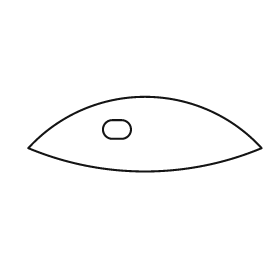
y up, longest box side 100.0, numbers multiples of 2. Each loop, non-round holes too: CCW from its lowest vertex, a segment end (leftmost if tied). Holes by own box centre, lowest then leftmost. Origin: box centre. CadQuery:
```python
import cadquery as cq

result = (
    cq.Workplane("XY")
    .moveTo(-50.0, -6.0)
    .threePointArc((0.0, -16.0), (50.0, -6.0))
    .threePointArc((0.0, 16.0), (-50.0, -6.0))
    .close()
    .moveTo(-14.0, -2.0)
    .lineTo(-10.0, -2.0)
    .threePointArc((-6.0, 2.0), (-10.0, 6.0))
    .lineTo(-14.0, 6.0)
    .threePointArc((-18.0, 2.0), (-14.0, -2.0))
    .close()
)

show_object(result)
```